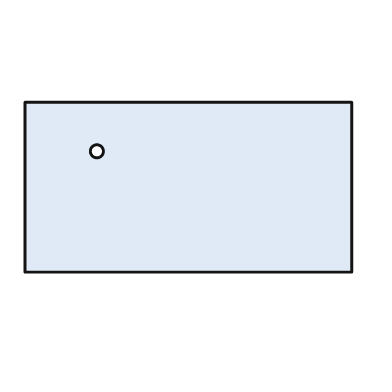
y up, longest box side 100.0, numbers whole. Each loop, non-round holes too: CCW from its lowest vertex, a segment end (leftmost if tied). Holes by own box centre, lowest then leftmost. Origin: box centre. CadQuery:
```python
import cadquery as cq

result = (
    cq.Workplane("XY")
    .moveTo(-50.0, -26.0)
    .lineTo(50.0, -26.0)
    .lineTo(50.0, 26.0)
    .lineTo(-50.0, 26.0)
    .close()
    .moveTo(-28.0, 11.0)
    .circle(2.0)
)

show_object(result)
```